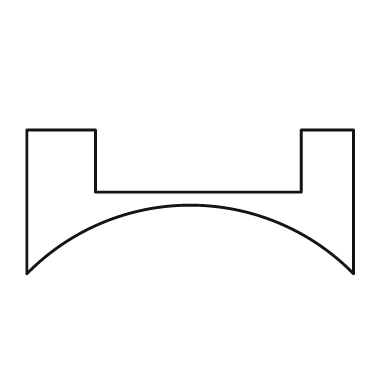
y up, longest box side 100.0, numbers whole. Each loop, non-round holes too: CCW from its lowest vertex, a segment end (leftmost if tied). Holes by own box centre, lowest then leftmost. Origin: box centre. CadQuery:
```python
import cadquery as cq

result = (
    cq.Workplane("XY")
    .moveTo(-50.0, -22.0)
    .threePointArc((0.0, -1.0), (50.0, -22.0))
    .lineTo(50.0, 22.0)
    .lineTo(34.0, 22.0)
    .lineTo(34.0, 3.0)
    .lineTo(-29.0, 3.0)
    .lineTo(-29.0, 22.0)
    .lineTo(-50.0, 22.0)
    .close()
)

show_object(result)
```